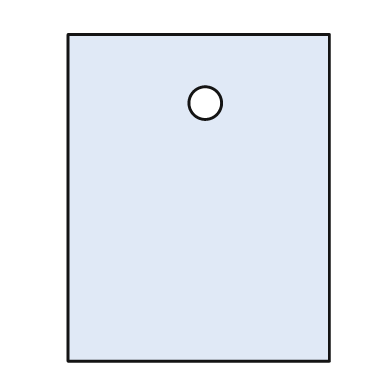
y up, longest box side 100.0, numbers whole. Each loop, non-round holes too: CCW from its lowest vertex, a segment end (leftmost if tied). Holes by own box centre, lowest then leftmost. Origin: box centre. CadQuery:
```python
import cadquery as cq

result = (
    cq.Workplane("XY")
    .moveTo(-40.0, -50.0)
    .lineTo(40.0, -50.0)
    .lineTo(40.0, 50.0)
    .lineTo(-40.0, 50.0)
    .close()
    .moveTo(2.0, 29.0)
    .circle(5.0)
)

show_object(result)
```